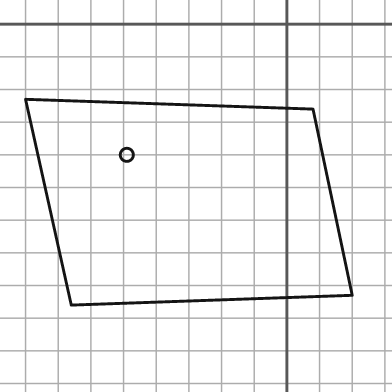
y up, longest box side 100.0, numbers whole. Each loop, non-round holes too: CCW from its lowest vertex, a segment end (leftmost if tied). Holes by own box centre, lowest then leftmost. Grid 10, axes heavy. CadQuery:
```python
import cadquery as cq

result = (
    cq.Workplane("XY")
    .moveTo(-66.0, -86.0)
    .lineTo(20.0, -83.0)
    .lineTo(8.0, -26.0)
    .lineTo(-80.0, -23.0)
    .close()
    .moveTo(-49.0, -40.0)
    .circle(2.0)
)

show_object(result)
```